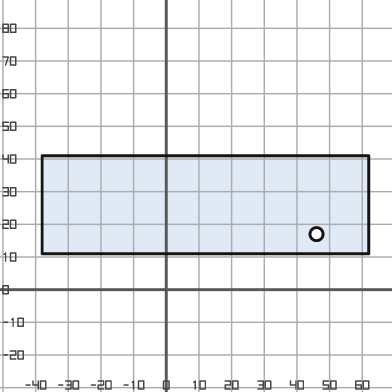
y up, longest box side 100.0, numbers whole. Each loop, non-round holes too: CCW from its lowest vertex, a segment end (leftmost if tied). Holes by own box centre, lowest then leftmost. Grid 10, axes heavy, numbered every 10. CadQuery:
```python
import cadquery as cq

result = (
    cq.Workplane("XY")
    .moveTo(-38.0, 11.0)
    .lineTo(62.0, 11.0)
    .lineTo(62.0, 41.0)
    .lineTo(-38.0, 41.0)
    .close()
    .moveTo(46.0, 17.0)
    .circle(2.0)
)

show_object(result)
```